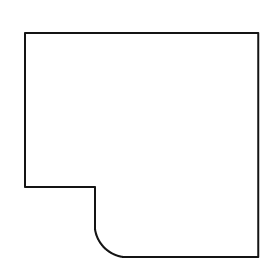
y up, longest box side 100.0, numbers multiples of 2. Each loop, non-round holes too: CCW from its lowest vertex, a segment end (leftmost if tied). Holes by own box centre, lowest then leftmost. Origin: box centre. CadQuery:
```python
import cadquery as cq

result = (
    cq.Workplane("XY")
    .moveTo(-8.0, -48.0)
    .lineTo(50.0, -48.0)
    .lineTo(50.0, 48.0)
    .lineTo(-50.0, 48.0)
    .lineTo(-50.0, -18.0)
    .lineTo(-20.0, -18.0)
    .lineTo(-20.0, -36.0)
    .threePointArc((-16.0, -44.0), (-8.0, -48.0))
    .close()
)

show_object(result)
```